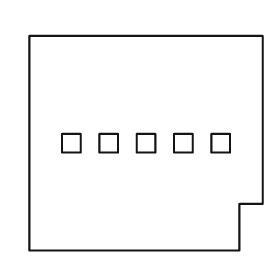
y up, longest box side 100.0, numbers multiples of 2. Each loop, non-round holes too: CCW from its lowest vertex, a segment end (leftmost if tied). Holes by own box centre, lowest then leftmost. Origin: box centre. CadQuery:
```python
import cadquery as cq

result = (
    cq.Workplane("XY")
    .moveTo(-50.0, -46.0)
    .lineTo(40.0, -46.0)
    .lineTo(40.0, -26.0)
    .lineTo(50.0, -26.0)
    .lineTo(50.0, 46.0)
    .lineTo(-50.0, 46.0)
    .close()
    .moveTo(-36.0, -4.0)
    .lineTo(-28.0, -4.0)
    .lineTo(-28.0, 4.0)
    .lineTo(-36.0, 4.0)
    .close()
    .moveTo(-20.0, -4.0)
    .lineTo(-12.0, -4.0)
    .lineTo(-12.0, 4.0)
    .lineTo(-20.0, 4.0)
    .close()
    .moveTo(-4.0, -4.0)
    .lineTo(4.0, -4.0)
    .lineTo(4.0, 4.0)
    .lineTo(-4.0, 4.0)
    .close()
    .moveTo(12.0, -4.0)
    .lineTo(20.0, -4.0)
    .lineTo(20.0, 4.0)
    .lineTo(12.0, 4.0)
    .close()
    .moveTo(28.0, -4.0)
    .lineTo(36.0, -4.0)
    .lineTo(36.0, 4.0)
    .lineTo(28.0, 4.0)
    .close()
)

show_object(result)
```